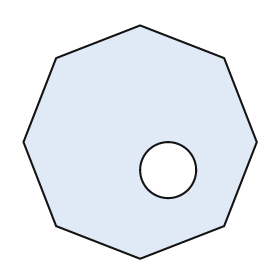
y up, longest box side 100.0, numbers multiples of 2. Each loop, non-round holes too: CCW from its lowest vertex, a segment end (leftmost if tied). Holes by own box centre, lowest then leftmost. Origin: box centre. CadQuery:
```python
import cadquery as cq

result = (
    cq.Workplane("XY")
    .moveTo(0.0, -50.0)
    .lineTo(36.0, -36.0)
    .lineTo(50.0, 0.0)
    .lineTo(36.0, 36.0)
    .lineTo(0.0, 50.0)
    .lineTo(-36.0, 36.0)
    .lineTo(-50.0, 0.0)
    .lineTo(-36.0, -36.0)
    .close()
    .moveTo(12.0, -12.0)
    .circle(12.0)
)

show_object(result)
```